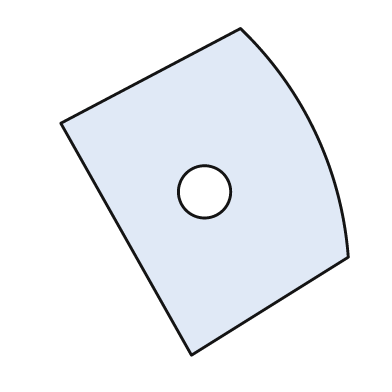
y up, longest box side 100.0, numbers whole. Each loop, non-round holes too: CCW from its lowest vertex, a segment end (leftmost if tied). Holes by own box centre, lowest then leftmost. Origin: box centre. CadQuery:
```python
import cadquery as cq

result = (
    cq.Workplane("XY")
    .moveTo(-4.0, -50.0)
    .lineTo(44.0, -20.0)
    .threePointArc((34.0, 18.0), (11.0, 50.0))
    .lineTo(-44.0, 21.0)
    .close()
    .moveTo(0.0, 0.0)
    .circle(8.0)
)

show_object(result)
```